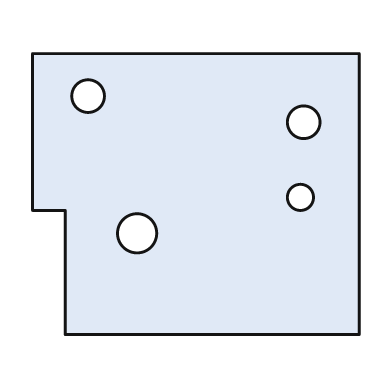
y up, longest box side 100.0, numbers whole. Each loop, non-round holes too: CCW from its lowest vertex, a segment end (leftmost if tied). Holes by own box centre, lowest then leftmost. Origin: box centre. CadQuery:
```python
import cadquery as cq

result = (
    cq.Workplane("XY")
    .moveTo(-40.0, -43.0)
    .lineTo(50.0, -43.0)
    .lineTo(50.0, 43.0)
    .lineTo(-50.0, 43.0)
    .lineTo(-50.0, -5.0)
    .lineTo(-40.0, -5.0)
    .close()
    .moveTo(-18.0, -12.0)
    .circle(6.0)
    .moveTo(32.0, -1.0)
    .circle(4.0)
    .moveTo(33.0, 22.0)
    .circle(5.0)
    .moveTo(-33.0, 30.0)
    .circle(5.0)
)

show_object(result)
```